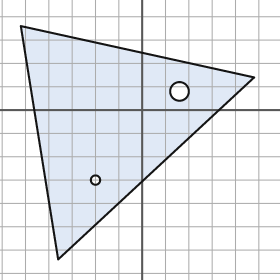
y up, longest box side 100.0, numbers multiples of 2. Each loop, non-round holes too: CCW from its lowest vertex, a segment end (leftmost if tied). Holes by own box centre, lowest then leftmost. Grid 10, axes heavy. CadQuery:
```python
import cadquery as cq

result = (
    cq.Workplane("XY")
    .moveTo(-36.0, -64.0)
    .lineTo(48.0, 14.0)
    .lineTo(-52.0, 36.0)
    .close()
    .moveTo(-20.0, -30.0)
    .circle(2.0)
    .moveTo(16.0, 8.0)
    .circle(4.0)
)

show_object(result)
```